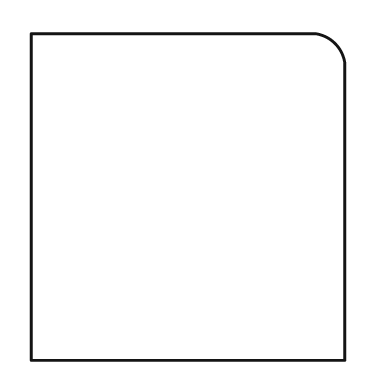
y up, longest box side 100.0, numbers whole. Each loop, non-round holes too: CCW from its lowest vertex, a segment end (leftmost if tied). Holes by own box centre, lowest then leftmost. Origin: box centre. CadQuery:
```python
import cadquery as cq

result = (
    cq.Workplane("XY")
    .moveTo(-48.0, -50.0)
    .lineTo(48.0, -50.0)
    .lineTo(48.0, 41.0)
    .threePointArc((45.0, 47.0), (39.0, 50.0))
    .lineTo(-48.0, 50.0)
    .close()
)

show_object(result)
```